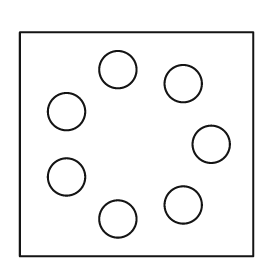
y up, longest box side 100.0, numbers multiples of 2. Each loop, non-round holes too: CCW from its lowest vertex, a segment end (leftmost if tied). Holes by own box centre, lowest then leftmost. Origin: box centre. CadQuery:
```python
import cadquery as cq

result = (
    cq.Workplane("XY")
    .moveTo(-50.0, -48.0)
    .lineTo(50.0, -48.0)
    .lineTo(50.0, 48.0)
    .lineTo(-50.0, 48.0)
    .close()
    .moveTo(-8.0, -32.0)
    .circle(8.0)
    .moveTo(20.0, -26.0)
    .circle(8.0)
    .moveTo(-30.0, -14.0)
    .circle(8.0)
    .moveTo(32.0, 0.0)
    .circle(8.0)
    .moveTo(-30.0, 14.0)
    .circle(8.0)
    .moveTo(20.0, 26.0)
    .circle(8.0)
    .moveTo(-8.0, 32.0)
    .circle(8.0)
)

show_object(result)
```